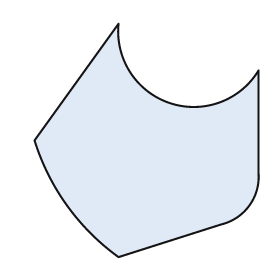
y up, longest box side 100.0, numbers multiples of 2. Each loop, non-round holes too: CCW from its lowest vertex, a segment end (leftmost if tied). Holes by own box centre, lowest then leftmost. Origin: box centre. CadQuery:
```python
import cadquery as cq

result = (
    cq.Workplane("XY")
    .moveTo(-12.0, -50.0)
    .lineTo(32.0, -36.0)
    .threePointArc((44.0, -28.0), (48.0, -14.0))
    .lineTo(48.0, 30.0)
    .threePointArc((10.0, 16.0), (-12.0, 50.0))
    .lineTo(-48.0, 0.0)
    .threePointArc((-34.0, -28.0), (-12.0, -50.0))
    .close()
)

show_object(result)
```